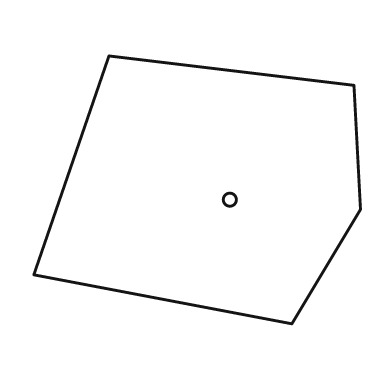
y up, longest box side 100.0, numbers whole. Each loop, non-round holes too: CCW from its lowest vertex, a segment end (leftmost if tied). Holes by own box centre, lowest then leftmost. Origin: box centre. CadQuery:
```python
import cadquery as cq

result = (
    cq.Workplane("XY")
    .moveTo(29.0, -41.0)
    .lineTo(50.0, -6.0)
    .lineTo(48.0, 32.0)
    .lineTo(-27.0, 41.0)
    .lineTo(-50.0, -26.0)
    .close()
    .moveTo(10.0, -3.0)
    .circle(2.0)
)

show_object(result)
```